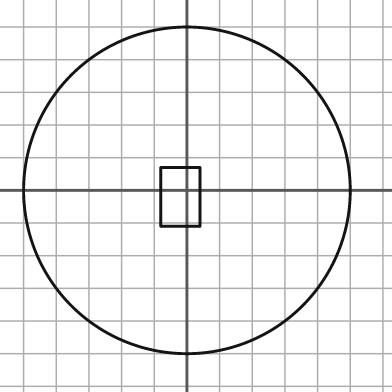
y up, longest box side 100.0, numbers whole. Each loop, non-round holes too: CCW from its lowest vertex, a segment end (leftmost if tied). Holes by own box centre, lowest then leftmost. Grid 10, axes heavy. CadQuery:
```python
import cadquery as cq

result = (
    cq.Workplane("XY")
    .moveTo(0.0, 0.0)
    .circle(50.0)
    .moveTo(-8.0, -11.0)
    .lineTo(4.0, -11.0)
    .lineTo(4.0, 7.0)
    .lineTo(-8.0, 7.0)
    .close()
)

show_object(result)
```